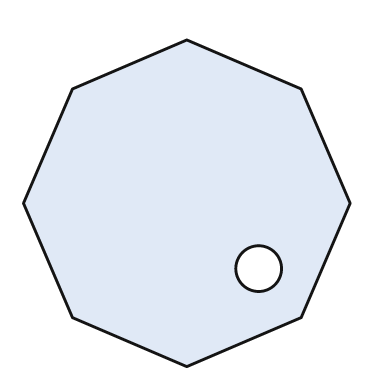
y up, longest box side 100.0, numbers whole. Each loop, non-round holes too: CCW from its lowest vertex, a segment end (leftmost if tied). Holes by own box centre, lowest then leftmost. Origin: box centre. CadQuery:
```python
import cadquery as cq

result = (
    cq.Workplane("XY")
    .moveTo(0.0, -50.0)
    .lineTo(35.0, -35.0)
    .lineTo(50.0, 0.0)
    .lineTo(35.0, 35.0)
    .lineTo(0.0, 50.0)
    .lineTo(-35.0, 35.0)
    .lineTo(-50.0, 0.0)
    .lineTo(-35.0, -35.0)
    .close()
    .moveTo(22.0, -20.0)
    .circle(7.0)
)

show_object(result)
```